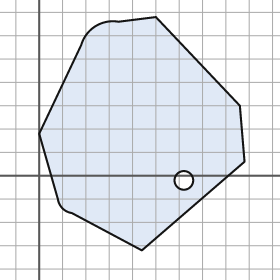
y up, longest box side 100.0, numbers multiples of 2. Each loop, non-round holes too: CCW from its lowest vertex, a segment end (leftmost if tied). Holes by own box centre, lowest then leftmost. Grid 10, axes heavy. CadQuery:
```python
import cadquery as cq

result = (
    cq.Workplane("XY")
    .moveTo(44.0, -32.0)
    .lineTo(88.0, 6.0)
    .lineTo(86.0, 30.0)
    .lineTo(50.0, 68.0)
    .lineTo(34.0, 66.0)
    .threePointArc((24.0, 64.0), (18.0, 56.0))
    .lineTo(0.0, 18.0)
    .lineTo(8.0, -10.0)
    .threePointArc((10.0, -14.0), (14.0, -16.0))
    .close()
    .moveTo(62.0, -2.0)
    .circle(4.0)
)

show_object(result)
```